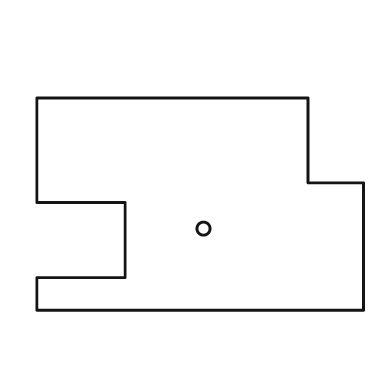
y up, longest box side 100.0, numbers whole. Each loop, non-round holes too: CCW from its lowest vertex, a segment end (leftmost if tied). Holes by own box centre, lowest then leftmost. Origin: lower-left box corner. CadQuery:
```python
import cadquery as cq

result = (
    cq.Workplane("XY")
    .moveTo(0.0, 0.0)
    .lineTo(100.0, 0.0)
    .lineTo(100.0, 39.0)
    .lineTo(83.0, 39.0)
    .lineTo(83.0, 65.0)
    .lineTo(0.0, 65.0)
    .lineTo(0.0, 33.0)
    .lineTo(27.0, 33.0)
    .lineTo(27.0, 10.0)
    .lineTo(0.0, 10.0)
    .close()
    .moveTo(51.0, 25.0)
    .circle(2.0)
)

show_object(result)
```